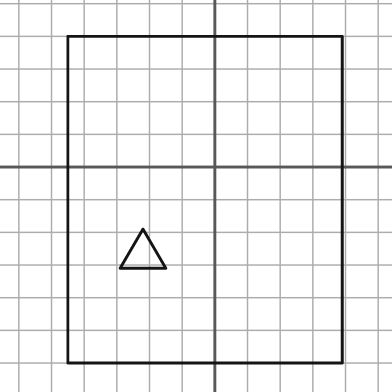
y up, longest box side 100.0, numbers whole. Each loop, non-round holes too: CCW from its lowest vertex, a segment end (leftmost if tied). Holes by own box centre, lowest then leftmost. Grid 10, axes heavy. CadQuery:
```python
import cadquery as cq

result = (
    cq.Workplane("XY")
    .moveTo(-45.0, -60.0)
    .lineTo(39.0, -60.0)
    .lineTo(39.0, 40.0)
    .lineTo(-45.0, 40.0)
    .close()
    .moveTo(-29.0, -31.0)
    .lineTo(-15.0, -31.0)
    .lineTo(-22.0, -19.0)
    .close()
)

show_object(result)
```